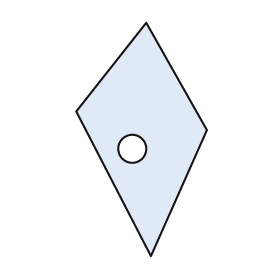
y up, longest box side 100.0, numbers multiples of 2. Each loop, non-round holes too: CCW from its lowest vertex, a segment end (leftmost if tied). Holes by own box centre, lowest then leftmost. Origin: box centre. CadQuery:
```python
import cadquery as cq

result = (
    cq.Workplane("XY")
    .moveTo(4.0, -50.0)
    .lineTo(28.0, 4.0)
    .lineTo(2.0, 50.0)
    .lineTo(-28.0, 12.0)
    .close()
    .moveTo(-4.0, -4.0)
    .circle(6.0)
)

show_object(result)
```